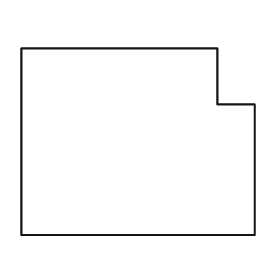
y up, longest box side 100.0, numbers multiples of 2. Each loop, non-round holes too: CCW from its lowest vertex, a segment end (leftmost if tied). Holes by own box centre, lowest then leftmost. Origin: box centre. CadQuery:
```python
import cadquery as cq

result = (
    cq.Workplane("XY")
    .moveTo(-50.0, -40.0)
    .lineTo(50.0, -40.0)
    .lineTo(50.0, 16.0)
    .lineTo(34.0, 16.0)
    .lineTo(34.0, 40.0)
    .lineTo(-50.0, 40.0)
    .close()
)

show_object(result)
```